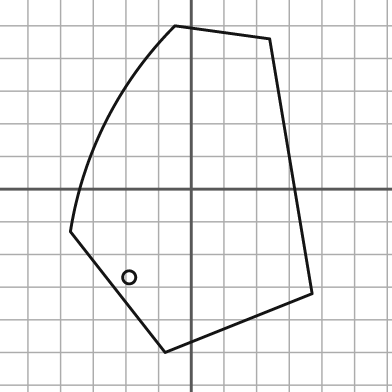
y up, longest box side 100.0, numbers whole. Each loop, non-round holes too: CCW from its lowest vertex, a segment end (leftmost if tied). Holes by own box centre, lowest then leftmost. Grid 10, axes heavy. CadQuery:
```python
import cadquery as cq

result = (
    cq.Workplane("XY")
    .moveTo(-8.0, -50.0)
    .lineTo(37.0, -32.0)
    .lineTo(24.0, 46.0)
    .lineTo(-5.0, 50.0)
    .threePointArc((-26.0, 21.0), (-37.0, -13.0))
    .close()
    .moveTo(-19.0, -27.0)
    .circle(2.0)
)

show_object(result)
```